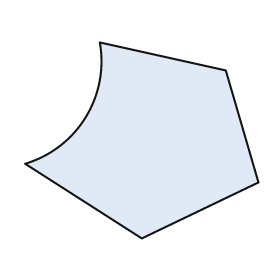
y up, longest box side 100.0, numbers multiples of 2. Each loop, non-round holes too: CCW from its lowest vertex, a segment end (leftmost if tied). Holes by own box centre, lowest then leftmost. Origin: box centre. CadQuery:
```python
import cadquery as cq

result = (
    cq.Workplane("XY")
    .moveTo(0.0, -42.0)
    .lineTo(50.0, -18.0)
    .lineTo(36.0, 30.0)
    .lineTo(-18.0, 42.0)
    .threePointArc((-24.0, 10.0), (-50.0, -10.0))
    .close()
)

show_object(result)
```